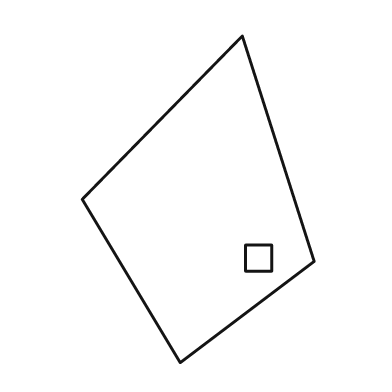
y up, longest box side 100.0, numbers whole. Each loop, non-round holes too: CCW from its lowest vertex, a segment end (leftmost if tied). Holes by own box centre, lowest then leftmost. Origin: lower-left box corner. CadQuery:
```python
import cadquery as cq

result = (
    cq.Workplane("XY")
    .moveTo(30.0, 0.0)
    .lineTo(71.0, 31.0)
    .lineTo(49.0, 100.0)
    .lineTo(0.0, 50.0)
    .close()
    .moveTo(50.0, 28.0)
    .lineTo(58.0, 28.0)
    .lineTo(58.0, 36.0)
    .lineTo(50.0, 36.0)
    .close()
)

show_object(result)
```